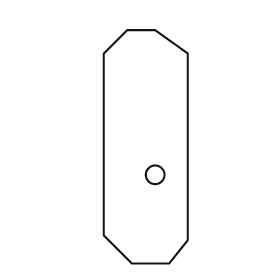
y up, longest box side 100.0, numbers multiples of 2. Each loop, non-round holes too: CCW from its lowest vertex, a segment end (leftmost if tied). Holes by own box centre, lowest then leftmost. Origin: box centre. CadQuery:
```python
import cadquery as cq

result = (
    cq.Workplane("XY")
    .moveTo(-6.0, -50.0)
    .lineTo(10.0, -50.0)
    .lineTo(18.0, -40.0)
    .lineTo(18.0, 40.0)
    .lineTo(4.0, 50.0)
    .lineTo(-8.0, 50.0)
    .lineTo(-18.0, 40.0)
    .lineTo(-18.0, -38.0)
    .close()
    .moveTo(4.0, -12.0)
    .circle(4.0)
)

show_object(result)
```